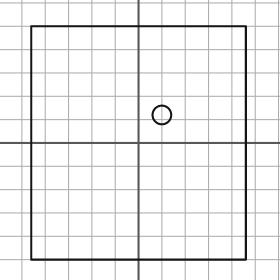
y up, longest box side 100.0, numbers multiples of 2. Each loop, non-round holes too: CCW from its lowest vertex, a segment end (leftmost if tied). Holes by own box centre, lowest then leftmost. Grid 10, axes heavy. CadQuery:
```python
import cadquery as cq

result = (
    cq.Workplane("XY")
    .moveTo(-46.0, -50.0)
    .lineTo(46.0, -50.0)
    .lineTo(46.0, 50.0)
    .lineTo(-46.0, 50.0)
    .close()
    .moveTo(10.0, 12.0)
    .circle(4.0)
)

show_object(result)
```